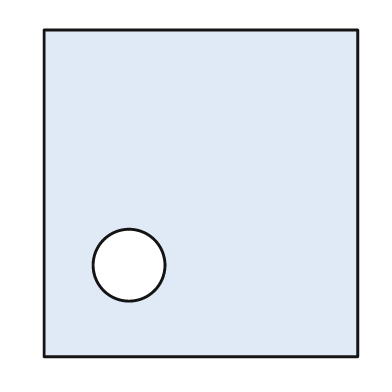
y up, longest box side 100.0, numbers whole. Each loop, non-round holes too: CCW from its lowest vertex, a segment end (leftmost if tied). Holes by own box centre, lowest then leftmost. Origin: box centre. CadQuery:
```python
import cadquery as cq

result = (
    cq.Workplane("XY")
    .moveTo(-48.0, -50.0)
    .lineTo(48.0, -50.0)
    .lineTo(48.0, 50.0)
    .lineTo(-48.0, 50.0)
    .close()
    .moveTo(-22.0, -22.0)
    .circle(11.0)
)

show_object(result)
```